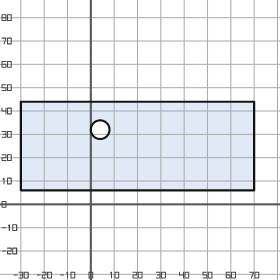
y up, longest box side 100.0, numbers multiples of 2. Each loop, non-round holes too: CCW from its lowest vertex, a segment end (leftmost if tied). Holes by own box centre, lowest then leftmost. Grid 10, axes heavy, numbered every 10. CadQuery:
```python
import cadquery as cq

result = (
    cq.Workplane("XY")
    .moveTo(-30.0, 6.0)
    .lineTo(70.0, 6.0)
    .lineTo(70.0, 44.0)
    .lineTo(-30.0, 44.0)
    .close()
    .moveTo(4.0, 32.0)
    .circle(4.0)
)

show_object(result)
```